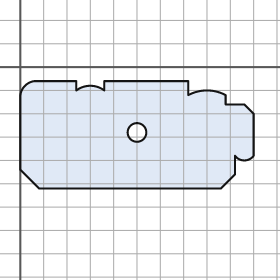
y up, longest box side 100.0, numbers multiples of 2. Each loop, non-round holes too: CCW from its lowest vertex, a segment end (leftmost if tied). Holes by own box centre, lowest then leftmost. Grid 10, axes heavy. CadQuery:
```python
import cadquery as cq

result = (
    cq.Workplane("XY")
    .moveTo(8.0, -52.0)
    .lineTo(86.0, -52.0)
    .lineTo(92.0, -46.0)
    .lineTo(92.0, -38.0)
    .threePointArc((96.0, -40.0), (100.0, -38.0))
    .lineTo(100.0, -20.0)
    .lineTo(96.0, -16.0)
    .lineTo(88.0, -16.0)
    .lineTo(88.0, -12.0)
    .threePointArc((80.0, -10.0), (72.0, -12.0))
    .lineTo(72.0, -6.0)
    .lineTo(36.0, -6.0)
    .lineTo(36.0, -10.0)
    .threePointArc((30.0, -8.0), (24.0, -10.0))
    .lineTo(24.0, -6.0)
    .lineTo(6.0, -6.0)
    .threePointArc((2.0, -8.0), (0.0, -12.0))
    .lineTo(0.0, -44.0)
    .close()
    .moveTo(50.0, -28.0)
    .circle(4.0)
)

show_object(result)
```